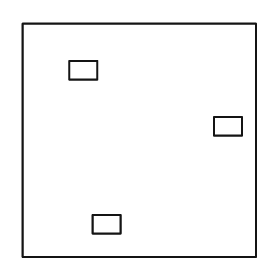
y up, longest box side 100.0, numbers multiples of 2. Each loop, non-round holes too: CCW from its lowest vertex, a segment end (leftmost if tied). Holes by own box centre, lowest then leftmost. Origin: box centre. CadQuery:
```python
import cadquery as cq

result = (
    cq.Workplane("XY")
    .moveTo(-50.0, -50.0)
    .lineTo(50.0, -50.0)
    .lineTo(50.0, 50.0)
    .lineTo(-50.0, 50.0)
    .close()
    .moveTo(-20.0, -40.0)
    .lineTo(-8.0, -40.0)
    .lineTo(-8.0, -32.0)
    .lineTo(-20.0, -32.0)
    .close()
    .moveTo(32.0, 2.0)
    .lineTo(44.0, 2.0)
    .lineTo(44.0, 10.0)
    .lineTo(32.0, 10.0)
    .close()
    .moveTo(-30.0, 26.0)
    .lineTo(-18.0, 26.0)
    .lineTo(-18.0, 34.0)
    .lineTo(-30.0, 34.0)
    .close()
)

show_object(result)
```